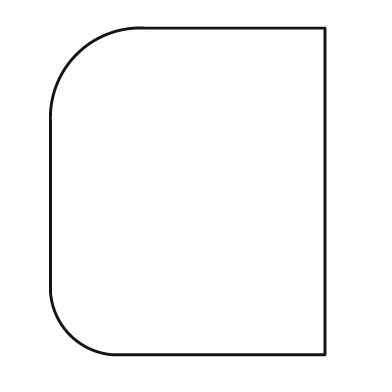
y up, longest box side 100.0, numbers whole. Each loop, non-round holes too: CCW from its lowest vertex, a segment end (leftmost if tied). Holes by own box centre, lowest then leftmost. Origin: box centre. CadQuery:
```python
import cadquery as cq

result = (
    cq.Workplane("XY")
    .moveTo(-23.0, -50.0)
    .lineTo(42.0, -50.0)
    .lineTo(42.0, 50.0)
    .lineTo(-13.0, 50.0)
    .threePointArc((-34.0, 42.0), (-42.0, 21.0))
    .lineTo(-42.0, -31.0)
    .threePointArc((-36.0, -44.0), (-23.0, -50.0))
    .close()
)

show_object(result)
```